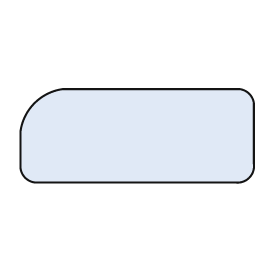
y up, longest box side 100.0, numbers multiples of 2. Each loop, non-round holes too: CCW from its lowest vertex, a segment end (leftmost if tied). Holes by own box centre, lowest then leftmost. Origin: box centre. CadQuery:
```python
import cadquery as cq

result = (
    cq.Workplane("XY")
    .moveTo(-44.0, -20.0)
    .lineTo(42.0, -20.0)
    .threePointArc((48.0, -18.0), (50.0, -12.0))
    .lineTo(50.0, 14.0)
    .threePointArc((48.0, 18.0), (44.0, 20.0))
    .lineTo(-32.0, 20.0)
    .threePointArc((-44.0, 14.0), (-50.0, 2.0))
    .lineTo(-50.0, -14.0)
    .threePointArc((-48.0, -18.0), (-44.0, -20.0))
    .close()
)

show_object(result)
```